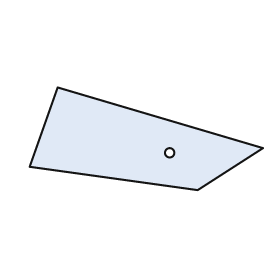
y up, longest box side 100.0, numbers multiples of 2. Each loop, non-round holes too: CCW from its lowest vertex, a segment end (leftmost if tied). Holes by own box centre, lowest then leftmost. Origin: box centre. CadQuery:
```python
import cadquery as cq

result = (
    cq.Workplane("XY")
    .moveTo(22.0, -22.0)
    .lineTo(50.0, -4.0)
    .lineTo(-38.0, 22.0)
    .lineTo(-50.0, -12.0)
    .close()
    .moveTo(10.0, -6.0)
    .circle(2.0)
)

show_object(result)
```